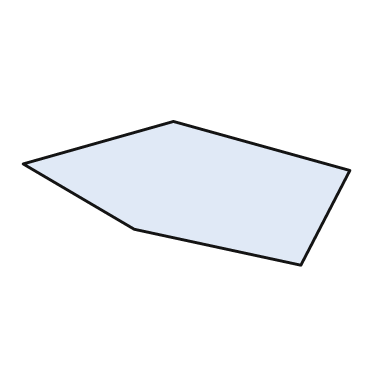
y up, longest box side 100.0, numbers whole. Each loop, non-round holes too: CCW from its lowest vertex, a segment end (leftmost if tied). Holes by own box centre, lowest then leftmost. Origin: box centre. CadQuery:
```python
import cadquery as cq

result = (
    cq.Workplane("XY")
    .moveTo(35.0, -22.0)
    .lineTo(50.0, 7.0)
    .lineTo(-4.0, 22.0)
    .lineTo(-50.0, 9.0)
    .lineTo(-16.0, -11.0)
    .close()
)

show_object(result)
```